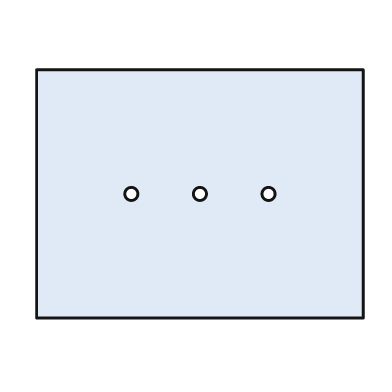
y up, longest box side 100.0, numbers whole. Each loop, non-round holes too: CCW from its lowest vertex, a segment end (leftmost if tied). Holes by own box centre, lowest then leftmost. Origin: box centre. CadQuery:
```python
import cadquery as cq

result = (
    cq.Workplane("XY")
    .moveTo(-50.0, -38.0)
    .lineTo(50.0, -38.0)
    .lineTo(50.0, 38.0)
    .lineTo(-50.0, 38.0)
    .close()
    .moveTo(-21.0, 0.0)
    .circle(2.0)
    .moveTo(0.0, 0.0)
    .circle(2.0)
    .moveTo(21.0, 0.0)
    .circle(2.0)
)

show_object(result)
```